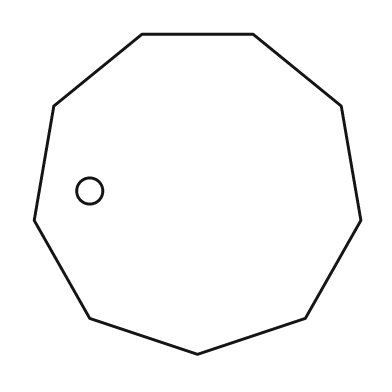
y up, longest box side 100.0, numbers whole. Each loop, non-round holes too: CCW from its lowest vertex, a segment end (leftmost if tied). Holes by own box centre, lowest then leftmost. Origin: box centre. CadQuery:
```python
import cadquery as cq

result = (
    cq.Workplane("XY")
    .moveTo(0.0, -49.0)
    .lineTo(33.0, -38.0)
    .lineTo(50.0, -8.0)
    .lineTo(44.0, 27.0)
    .lineTo(17.0, 49.0)
    .lineTo(-17.0, 49.0)
    .lineTo(-44.0, 27.0)
    .lineTo(-50.0, -8.0)
    .lineTo(-33.0, -38.0)
    .close()
    .moveTo(-33.0, 1.0)
    .circle(4.0)
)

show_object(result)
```